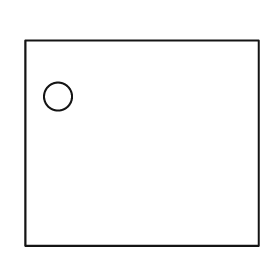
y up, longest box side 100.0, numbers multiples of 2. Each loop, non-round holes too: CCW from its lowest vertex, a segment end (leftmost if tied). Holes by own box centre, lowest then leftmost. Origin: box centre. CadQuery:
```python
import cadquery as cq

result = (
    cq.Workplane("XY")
    .moveTo(-50.0, -44.0)
    .lineTo(50.0, -44.0)
    .lineTo(50.0, 44.0)
    .lineTo(-50.0, 44.0)
    .close()
    .moveTo(-36.0, 20.0)
    .circle(6.0)
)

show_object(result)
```